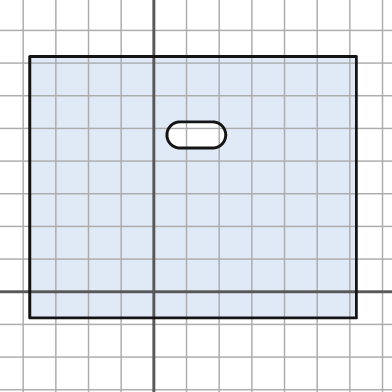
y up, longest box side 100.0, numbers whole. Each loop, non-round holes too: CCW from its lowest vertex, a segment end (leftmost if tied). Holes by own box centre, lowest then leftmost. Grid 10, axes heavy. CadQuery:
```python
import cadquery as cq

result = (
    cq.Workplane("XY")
    .moveTo(-38.0, -8.0)
    .lineTo(62.0, -8.0)
    .lineTo(62.0, 72.0)
    .lineTo(-38.0, 72.0)
    .close()
    .moveTo(8.0, 44.0)
    .lineTo(18.0, 44.0)
    .threePointArc((22.0, 48.0), (18.0, 52.0))
    .lineTo(8.0, 52.0)
    .threePointArc((4.0, 48.0), (8.0, 44.0))
    .close()
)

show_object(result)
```